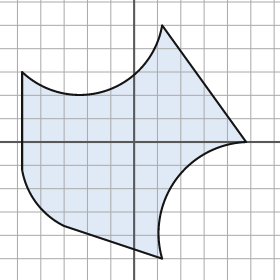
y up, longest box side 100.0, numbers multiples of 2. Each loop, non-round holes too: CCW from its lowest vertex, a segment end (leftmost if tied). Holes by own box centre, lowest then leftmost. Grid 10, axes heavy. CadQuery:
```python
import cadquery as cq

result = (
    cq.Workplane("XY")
    .moveTo(12.0, -50.0)
    .threePointArc((18.0, -16.0), (48.0, 0.0))
    .lineTo(12.0, 50.0)
    .threePointArc((-12.0, 22.0), (-48.0, 30.0))
    .lineTo(-48.0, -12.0)
    .threePointArc((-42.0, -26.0), (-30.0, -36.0))
    .close()
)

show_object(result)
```